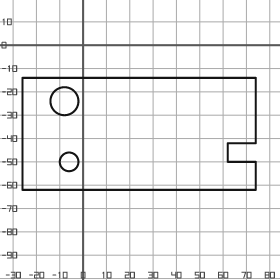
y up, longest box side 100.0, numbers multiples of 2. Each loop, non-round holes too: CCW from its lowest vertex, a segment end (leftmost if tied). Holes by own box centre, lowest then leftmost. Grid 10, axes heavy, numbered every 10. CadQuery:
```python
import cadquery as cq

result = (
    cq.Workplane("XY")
    .moveTo(-26.0, -62.0)
    .lineTo(74.0, -62.0)
    .lineTo(74.0, -50.0)
    .lineTo(62.0, -50.0)
    .lineTo(62.0, -42.0)
    .lineTo(74.0, -42.0)
    .lineTo(74.0, -14.0)
    .lineTo(-26.0, -14.0)
    .close()
    .moveTo(-6.0, -50.0)
    .circle(4.0)
    .moveTo(-8.0, -24.0)
    .circle(6.0)
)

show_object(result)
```